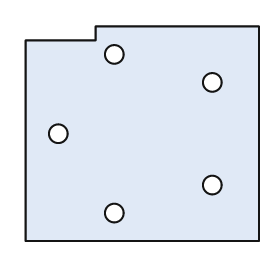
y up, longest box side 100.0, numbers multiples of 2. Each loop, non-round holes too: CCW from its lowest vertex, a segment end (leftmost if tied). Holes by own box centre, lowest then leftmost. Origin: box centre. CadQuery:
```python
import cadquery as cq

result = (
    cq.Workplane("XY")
    .moveTo(-50.0, -46.0)
    .lineTo(50.0, -46.0)
    .lineTo(50.0, 46.0)
    .lineTo(-20.0, 46.0)
    .lineTo(-20.0, 40.0)
    .lineTo(-50.0, 40.0)
    .close()
    .moveTo(-12.0, -34.0)
    .circle(4.0)
    .moveTo(30.0, -22.0)
    .circle(4.0)
    .moveTo(-36.0, 0.0)
    .circle(4.0)
    .moveTo(30.0, 22.0)
    .circle(4.0)
    .moveTo(-12.0, 34.0)
    .circle(4.0)
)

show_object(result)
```